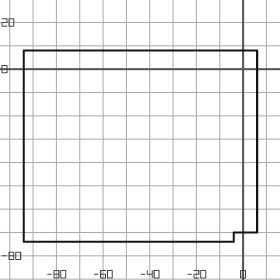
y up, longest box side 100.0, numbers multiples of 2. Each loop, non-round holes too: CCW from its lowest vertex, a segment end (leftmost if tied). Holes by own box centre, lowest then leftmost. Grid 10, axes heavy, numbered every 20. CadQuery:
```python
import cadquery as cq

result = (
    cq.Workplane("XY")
    .moveTo(-94.0, -74.0)
    .lineTo(-4.0, -74.0)
    .lineTo(-4.0, -70.0)
    .lineTo(6.0, -70.0)
    .lineTo(6.0, 8.0)
    .lineTo(-94.0, 8.0)
    .close()
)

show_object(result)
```